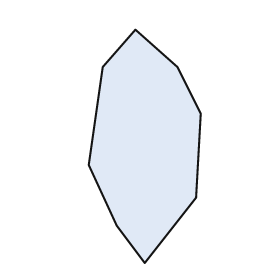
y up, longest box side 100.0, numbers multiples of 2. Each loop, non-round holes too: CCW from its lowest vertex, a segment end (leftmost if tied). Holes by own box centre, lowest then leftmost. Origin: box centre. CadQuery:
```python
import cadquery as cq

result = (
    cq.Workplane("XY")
    .moveTo(0.0, -50.0)
    .lineTo(22.0, -22.0)
    .lineTo(24.0, 14.0)
    .lineTo(14.0, 34.0)
    .lineTo(-4.0, 50.0)
    .lineTo(-18.0, 34.0)
    .lineTo(-24.0, -8.0)
    .lineTo(-12.0, -34.0)
    .close()
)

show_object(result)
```